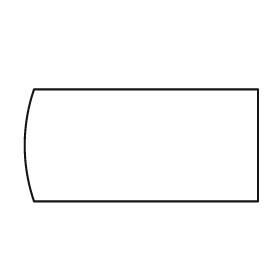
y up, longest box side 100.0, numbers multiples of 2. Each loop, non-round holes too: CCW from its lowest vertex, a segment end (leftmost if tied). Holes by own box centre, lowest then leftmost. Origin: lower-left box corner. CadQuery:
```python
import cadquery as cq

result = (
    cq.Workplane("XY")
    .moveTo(4.0, 0.0)
    .lineTo(100.0, 0.0)
    .lineTo(100.0, 48.0)
    .lineTo(4.0, 48.0)
    .threePointArc((0.0, 24.0), (4.0, 0.0))
    .close()
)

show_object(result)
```